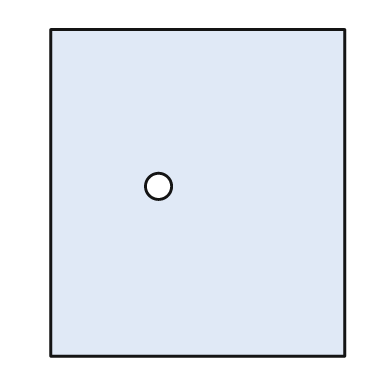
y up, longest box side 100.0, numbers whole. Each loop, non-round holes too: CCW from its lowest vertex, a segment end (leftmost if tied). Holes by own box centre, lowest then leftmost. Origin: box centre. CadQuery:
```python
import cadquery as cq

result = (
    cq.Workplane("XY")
    .moveTo(-45.0, -50.0)
    .lineTo(45.0, -50.0)
    .lineTo(45.0, 50.0)
    .lineTo(-45.0, 50.0)
    .close()
    .moveTo(-12.0, 2.0)
    .circle(4.0)
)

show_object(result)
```